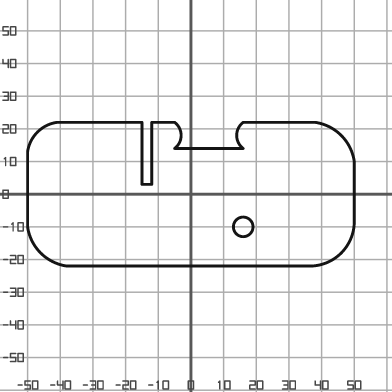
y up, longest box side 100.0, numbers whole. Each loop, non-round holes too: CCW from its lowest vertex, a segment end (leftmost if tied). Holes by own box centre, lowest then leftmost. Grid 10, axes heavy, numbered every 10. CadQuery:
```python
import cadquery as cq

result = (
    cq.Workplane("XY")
    .moveTo(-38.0, -22.0)
    .lineTo(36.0, -22.0)
    .threePointArc((46.0, -18.0), (50.0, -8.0))
    .lineTo(50.0, 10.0)
    .threePointArc((46.0, 18.0), (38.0, 22.0))
    .lineTo(16.0, 22.0)
    .threePointArc((14.0, 18.0), (16.0, 14.0))
    .lineTo(-5.0, 14.0)
    .threePointArc((-3.0, 18.0), (-5.0, 22.0))
    .lineTo(-12.0, 22.0)
    .lineTo(-12.0, 3.0)
    .lineTo(-15.0, 3.0)
    .lineTo(-15.0, 22.0)
    .lineTo(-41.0, 22.0)
    .threePointArc((-47.0, 19.0), (-50.0, 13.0))
    .lineTo(-50.0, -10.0)
    .threePointArc((-46.0, -18.0), (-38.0, -22.0))
    .close()
    .moveTo(16.0, -10.0)
    .circle(3.0)
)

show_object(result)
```